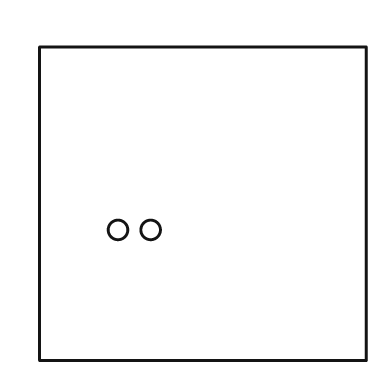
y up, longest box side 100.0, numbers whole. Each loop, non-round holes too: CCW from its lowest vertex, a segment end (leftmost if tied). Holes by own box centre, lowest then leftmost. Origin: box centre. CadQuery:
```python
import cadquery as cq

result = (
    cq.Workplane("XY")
    .moveTo(-50.0, -48.0)
    .lineTo(50.0, -48.0)
    .lineTo(50.0, 48.0)
    .lineTo(-50.0, 48.0)
    .close()
    .moveTo(-26.0, -8.0)
    .circle(3.0)
    .moveTo(-16.0, -8.0)
    .circle(3.0)
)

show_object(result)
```